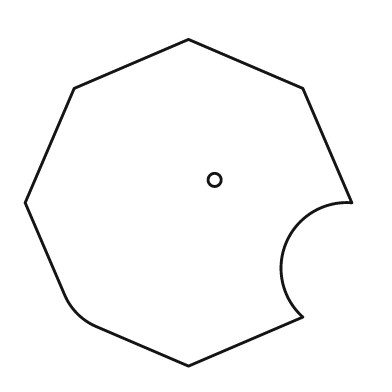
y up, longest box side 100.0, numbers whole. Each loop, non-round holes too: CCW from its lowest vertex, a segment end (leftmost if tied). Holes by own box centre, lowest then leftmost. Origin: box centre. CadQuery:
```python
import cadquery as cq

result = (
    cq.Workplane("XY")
    .moveTo(0.0, -50.0)
    .lineTo(35.0, -35.0)
    .threePointArc((30.0, -12.0), (50.0, 0.0))
    .lineTo(35.0, 35.0)
    .lineTo(0.0, 50.0)
    .lineTo(-35.0, 35.0)
    .lineTo(-50.0, 0.0)
    .lineTo(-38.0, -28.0)
    .threePointArc((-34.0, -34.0), (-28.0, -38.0))
    .close()
    .moveTo(8.0, 7.0)
    .circle(2.0)
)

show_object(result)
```